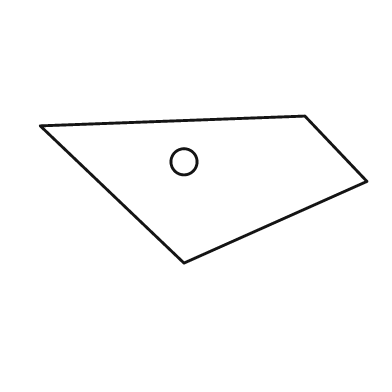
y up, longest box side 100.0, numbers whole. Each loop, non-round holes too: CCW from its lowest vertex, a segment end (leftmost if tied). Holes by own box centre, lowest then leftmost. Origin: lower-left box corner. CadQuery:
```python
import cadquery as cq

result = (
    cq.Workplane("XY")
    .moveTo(44.0, 0.0)
    .lineTo(100.0, 25.0)
    .lineTo(81.0, 45.0)
    .lineTo(0.0, 42.0)
    .close()
    .moveTo(44.0, 31.0)
    .circle(4.0)
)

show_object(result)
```